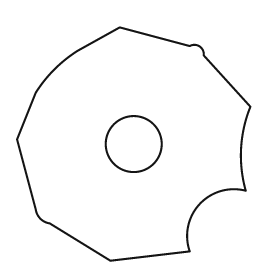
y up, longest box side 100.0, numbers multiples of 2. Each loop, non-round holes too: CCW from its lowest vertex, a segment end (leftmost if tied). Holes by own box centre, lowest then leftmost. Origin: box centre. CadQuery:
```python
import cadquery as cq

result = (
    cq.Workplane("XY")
    .moveTo(-10.0, -50.0)
    .lineTo(24.0, -46.0)
    .threePointArc((28.0, -26.0), (48.0, -20.0))
    .threePointArc((46.0, -2.0), (50.0, 16.0))
    .lineTo(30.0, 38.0)
    .threePointArc((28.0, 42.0), (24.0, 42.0))
    .lineTo(-6.0, 50.0)
    .lineTo(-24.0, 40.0)
    .threePointArc((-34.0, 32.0), (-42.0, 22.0))
    .lineTo(-50.0, 2.0)
    .lineTo(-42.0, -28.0)
    .threePointArc((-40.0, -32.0), (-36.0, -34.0))
    .close()
    .moveTo(0.0, 0.0)
    .circle(12.0)
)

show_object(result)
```